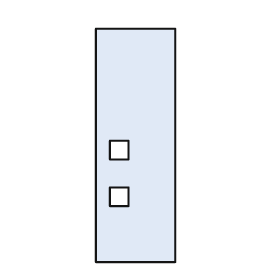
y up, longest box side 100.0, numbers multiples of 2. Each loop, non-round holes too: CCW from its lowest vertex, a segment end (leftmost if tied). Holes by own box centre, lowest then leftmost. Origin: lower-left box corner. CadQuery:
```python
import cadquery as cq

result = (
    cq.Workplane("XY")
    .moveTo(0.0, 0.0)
    .lineTo(34.0, 0.0)
    .lineTo(34.0, 100.0)
    .lineTo(0.0, 100.0)
    .close()
    .moveTo(6.0, 24.0)
    .lineTo(14.0, 24.0)
    .lineTo(14.0, 32.0)
    .lineTo(6.0, 32.0)
    .close()
    .moveTo(6.0, 44.0)
    .lineTo(14.0, 44.0)
    .lineTo(14.0, 52.0)
    .lineTo(6.0, 52.0)
    .close()
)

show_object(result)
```